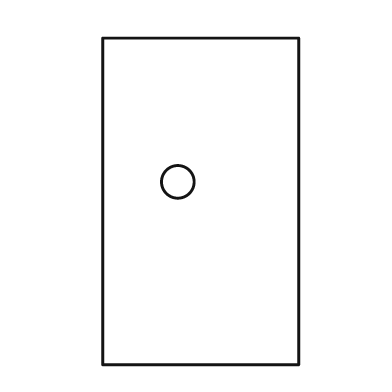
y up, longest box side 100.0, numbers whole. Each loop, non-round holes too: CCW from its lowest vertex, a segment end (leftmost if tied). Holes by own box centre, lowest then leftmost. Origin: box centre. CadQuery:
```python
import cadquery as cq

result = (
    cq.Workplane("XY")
    .moveTo(-30.0, -50.0)
    .lineTo(30.0, -50.0)
    .lineTo(30.0, 50.0)
    .lineTo(-30.0, 50.0)
    .close()
    .moveTo(-7.0, 6.0)
    .circle(5.0)
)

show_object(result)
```